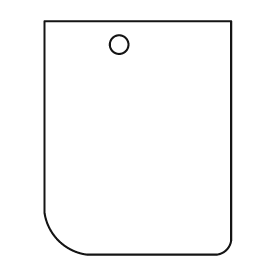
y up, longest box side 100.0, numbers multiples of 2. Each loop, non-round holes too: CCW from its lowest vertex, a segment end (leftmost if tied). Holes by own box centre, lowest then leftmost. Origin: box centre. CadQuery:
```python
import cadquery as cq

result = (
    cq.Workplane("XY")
    .moveTo(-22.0, -50.0)
    .lineTo(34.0, -50.0)
    .threePointArc((38.0, -48.0), (40.0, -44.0))
    .lineTo(40.0, 50.0)
    .lineTo(-40.0, 50.0)
    .lineTo(-40.0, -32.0)
    .threePointArc((-34.0, -44.0), (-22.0, -50.0))
    .close()
    .moveTo(-8.0, 40.0)
    .circle(4.0)
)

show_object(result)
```